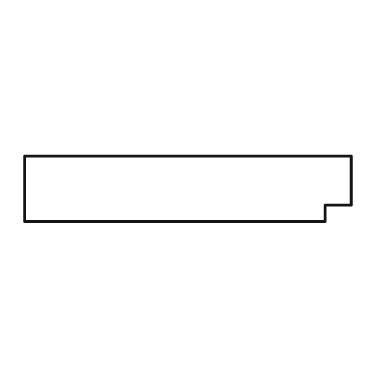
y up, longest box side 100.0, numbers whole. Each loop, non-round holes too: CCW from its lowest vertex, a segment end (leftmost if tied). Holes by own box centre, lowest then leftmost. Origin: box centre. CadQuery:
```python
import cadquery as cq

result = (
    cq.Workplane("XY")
    .moveTo(-50.0, -10.0)
    .lineTo(42.0, -10.0)
    .lineTo(42.0, -5.0)
    .lineTo(50.0, -5.0)
    .lineTo(50.0, 10.0)
    .lineTo(-50.0, 10.0)
    .close()
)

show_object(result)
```